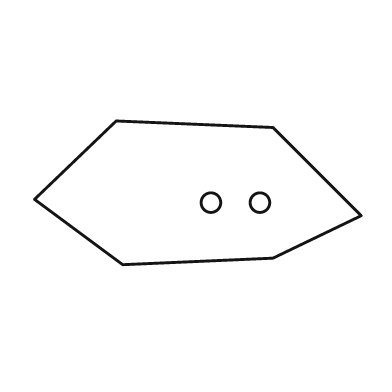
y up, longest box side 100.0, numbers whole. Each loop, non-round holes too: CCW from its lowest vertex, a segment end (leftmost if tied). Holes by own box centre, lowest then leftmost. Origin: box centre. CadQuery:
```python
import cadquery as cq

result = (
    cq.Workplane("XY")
    .moveTo(-23.0, -22.0)
    .lineTo(23.0, -20.0)
    .lineTo(50.0, -7.0)
    .lineTo(23.0, 20.0)
    .lineTo(-25.0, 22.0)
    .lineTo(-50.0, -2.0)
    .close()
    .moveTo(4.0, -3.0)
    .circle(3.0)
    .moveTo(19.0, -3.0)
    .circle(3.0)
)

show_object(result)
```